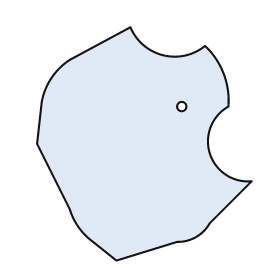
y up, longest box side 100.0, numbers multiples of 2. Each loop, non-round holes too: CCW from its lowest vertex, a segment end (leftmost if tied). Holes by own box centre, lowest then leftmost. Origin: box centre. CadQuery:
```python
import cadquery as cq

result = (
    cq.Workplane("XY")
    .moveTo(-12.0, -50.0)
    .lineTo(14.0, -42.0)
    .threePointArc((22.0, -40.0), (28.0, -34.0))
    .lineTo(46.0, -16.0)
    .threePointArc((28.0, -4.0), (36.0, 16.0))
    .threePointArc((34.0, 30.0), (26.0, 42.0))
    .threePointArc((8.0, 38.0), (-6.0, 50.0))
    .lineTo(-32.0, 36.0)
    .threePointArc((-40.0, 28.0), (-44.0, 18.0))
    .lineTo(-46.0, 0.0)
    .lineTo(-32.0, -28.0)
    .threePointArc((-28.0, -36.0), (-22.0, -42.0))
    .close()
    .moveTo(16.0, 16.0)
    .circle(2.0)
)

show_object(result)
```